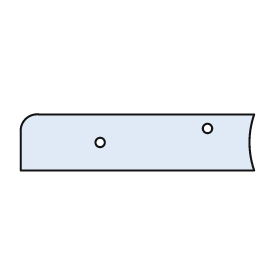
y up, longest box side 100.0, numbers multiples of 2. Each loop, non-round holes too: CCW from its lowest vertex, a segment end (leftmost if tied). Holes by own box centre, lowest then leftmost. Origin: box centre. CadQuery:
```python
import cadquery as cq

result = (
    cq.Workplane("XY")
    .moveTo(-50.0, -12.0)
    .lineTo(50.0, -12.0)
    .threePointArc((48.0, 0.0), (50.0, 12.0))
    .lineTo(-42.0, 12.0)
    .threePointArc((-48.0, 10.0), (-50.0, 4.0))
    .close()
    .moveTo(-16.0, 0.0)
    .circle(2.0)
    .moveTo(30.0, 6.0)
    .circle(2.0)
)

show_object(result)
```